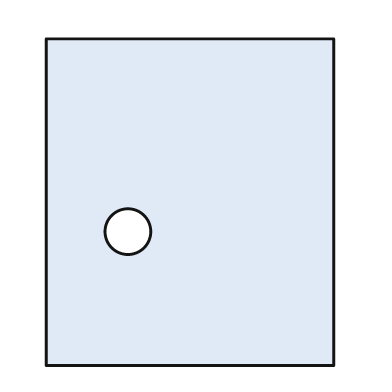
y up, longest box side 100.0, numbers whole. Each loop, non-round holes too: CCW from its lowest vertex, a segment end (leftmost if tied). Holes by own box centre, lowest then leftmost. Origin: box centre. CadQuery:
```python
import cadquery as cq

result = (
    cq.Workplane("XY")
    .moveTo(-44.0, -50.0)
    .lineTo(44.0, -50.0)
    .lineTo(44.0, 50.0)
    .lineTo(-44.0, 50.0)
    .close()
    .moveTo(-19.0, -9.0)
    .circle(7.0)
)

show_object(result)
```